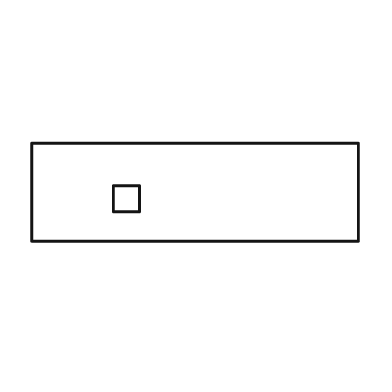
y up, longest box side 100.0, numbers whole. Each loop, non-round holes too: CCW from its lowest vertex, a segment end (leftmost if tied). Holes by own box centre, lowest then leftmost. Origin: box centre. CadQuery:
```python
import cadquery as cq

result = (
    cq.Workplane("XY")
    .moveTo(-50.0, -15.0)
    .lineTo(50.0, -15.0)
    .lineTo(50.0, 15.0)
    .lineTo(-50.0, 15.0)
    .close()
    .moveTo(-25.0, -6.0)
    .lineTo(-17.0, -6.0)
    .lineTo(-17.0, 2.0)
    .lineTo(-25.0, 2.0)
    .close()
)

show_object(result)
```